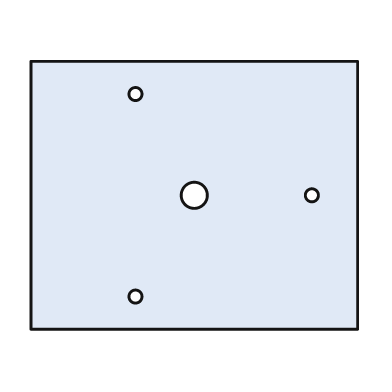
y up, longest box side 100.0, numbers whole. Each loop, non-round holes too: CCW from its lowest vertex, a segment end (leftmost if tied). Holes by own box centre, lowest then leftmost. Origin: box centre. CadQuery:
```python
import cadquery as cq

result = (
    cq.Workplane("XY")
    .moveTo(-50.0, -41.0)
    .lineTo(50.0, -41.0)
    .lineTo(50.0, 41.0)
    .lineTo(-50.0, 41.0)
    .close()
    .moveTo(-18.0, -31.0)
    .circle(2.0)
    .moveTo(0.0, 0.0)
    .circle(4.0)
    .moveTo(36.0, 0.0)
    .circle(2.0)
    .moveTo(-18.0, 31.0)
    .circle(2.0)
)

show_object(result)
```